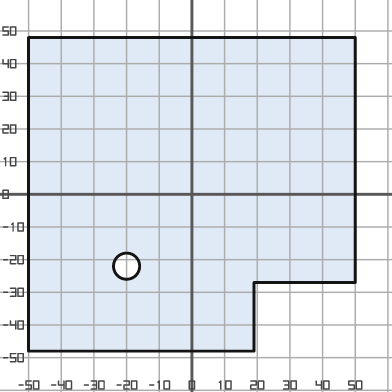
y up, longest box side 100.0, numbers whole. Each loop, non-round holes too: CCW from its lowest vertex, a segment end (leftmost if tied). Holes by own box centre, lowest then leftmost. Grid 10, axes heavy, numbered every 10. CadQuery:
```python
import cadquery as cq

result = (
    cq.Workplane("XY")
    .moveTo(-50.0, -48.0)
    .lineTo(19.0, -48.0)
    .lineTo(19.0, -27.0)
    .lineTo(50.0, -27.0)
    .lineTo(50.0, 48.0)
    .lineTo(-50.0, 48.0)
    .close()
    .moveTo(-20.0, -22.0)
    .circle(4.0)
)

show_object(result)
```